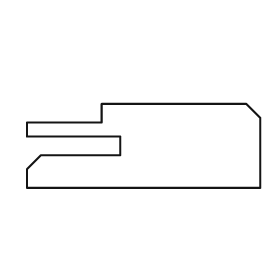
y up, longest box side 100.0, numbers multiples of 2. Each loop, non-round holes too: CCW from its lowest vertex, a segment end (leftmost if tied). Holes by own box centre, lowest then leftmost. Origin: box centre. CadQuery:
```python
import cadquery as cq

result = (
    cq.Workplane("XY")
    .moveTo(-50.0, -18.0)
    .lineTo(50.0, -18.0)
    .lineTo(50.0, 12.0)
    .lineTo(44.0, 18.0)
    .lineTo(-18.0, 18.0)
    .lineTo(-18.0, 10.0)
    .lineTo(-50.0, 10.0)
    .lineTo(-50.0, 4.0)
    .lineTo(-10.0, 4.0)
    .lineTo(-10.0, -4.0)
    .lineTo(-44.0, -4.0)
    .lineTo(-50.0, -10.0)
    .close()
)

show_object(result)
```